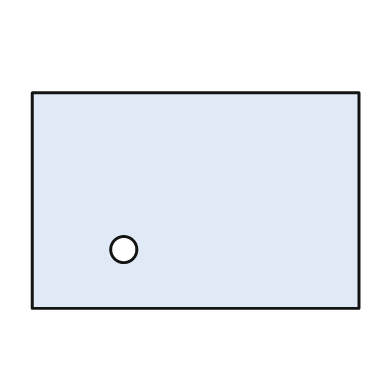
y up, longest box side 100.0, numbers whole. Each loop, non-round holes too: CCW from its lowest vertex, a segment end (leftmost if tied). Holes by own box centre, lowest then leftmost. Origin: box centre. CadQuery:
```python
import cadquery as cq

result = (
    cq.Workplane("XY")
    .moveTo(-50.0, -33.0)
    .lineTo(50.0, -33.0)
    .lineTo(50.0, 33.0)
    .lineTo(-50.0, 33.0)
    .close()
    .moveTo(-22.0, -15.0)
    .circle(4.0)
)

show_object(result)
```